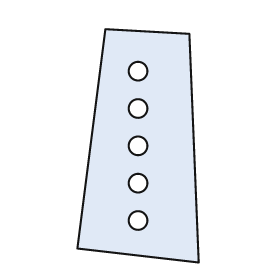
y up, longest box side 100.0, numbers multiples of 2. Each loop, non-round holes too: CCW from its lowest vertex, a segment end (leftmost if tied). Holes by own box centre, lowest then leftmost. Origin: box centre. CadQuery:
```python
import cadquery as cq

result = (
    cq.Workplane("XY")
    .moveTo(26.0, -50.0)
    .lineTo(22.0, 48.0)
    .lineTo(-14.0, 50.0)
    .lineTo(-26.0, -44.0)
    .close()
    .moveTo(0.0, -32.0)
    .circle(4.0)
    .moveTo(0.0, -16.0)
    .circle(4.0)
    .moveTo(0.0, 0.0)
    .circle(4.0)
    .moveTo(0.0, 16.0)
    .circle(4.0)
    .moveTo(0.0, 32.0)
    .circle(4.0)
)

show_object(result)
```